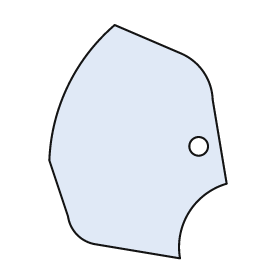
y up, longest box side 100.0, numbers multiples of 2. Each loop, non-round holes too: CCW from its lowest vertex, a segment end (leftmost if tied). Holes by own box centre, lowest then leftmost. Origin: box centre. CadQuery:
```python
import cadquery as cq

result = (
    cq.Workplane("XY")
    .moveTo(18.0, -50.0)
    .threePointArc((22.0, -30.0), (38.0, -18.0))
    .lineTo(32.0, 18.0)
    .threePointArc((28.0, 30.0), (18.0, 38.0))
    .lineTo(-10.0, 50.0)
    .threePointArc((-30.0, 24.0), (-38.0, -8.0))
    .lineTo(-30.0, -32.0)
    .threePointArc((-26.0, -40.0), (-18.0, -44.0))
    .close()
    .moveTo(26.0, -2.0)
    .circle(4.0)
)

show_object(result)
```